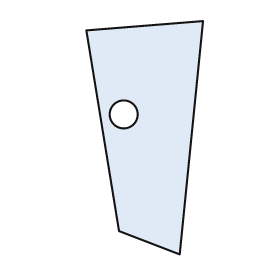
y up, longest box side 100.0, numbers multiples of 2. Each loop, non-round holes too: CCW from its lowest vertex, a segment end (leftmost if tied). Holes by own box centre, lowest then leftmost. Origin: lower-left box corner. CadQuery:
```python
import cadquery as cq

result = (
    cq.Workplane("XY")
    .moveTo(40.0, 0.0)
    .lineTo(50.0, 100.0)
    .lineTo(0.0, 96.0)
    .lineTo(14.0, 10.0)
    .close()
    .moveTo(16.0, 60.0)
    .circle(6.0)
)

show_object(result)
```